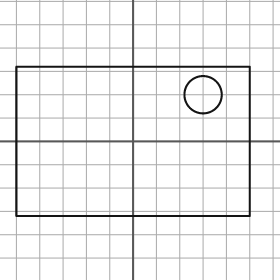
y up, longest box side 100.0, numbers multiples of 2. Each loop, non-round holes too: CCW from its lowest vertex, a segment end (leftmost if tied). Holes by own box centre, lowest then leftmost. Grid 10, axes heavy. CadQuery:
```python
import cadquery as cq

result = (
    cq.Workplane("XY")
    .moveTo(-50.0, -32.0)
    .lineTo(50.0, -32.0)
    .lineTo(50.0, 32.0)
    .lineTo(-50.0, 32.0)
    .close()
    .moveTo(30.0, 20.0)
    .circle(8.0)
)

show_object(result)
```